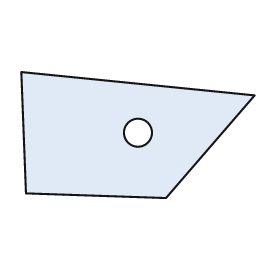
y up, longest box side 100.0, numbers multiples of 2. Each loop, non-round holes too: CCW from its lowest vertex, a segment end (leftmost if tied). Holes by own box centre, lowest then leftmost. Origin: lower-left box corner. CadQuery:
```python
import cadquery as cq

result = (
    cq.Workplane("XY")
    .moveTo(62.0, 0.0)
    .lineTo(100.0, 44.0)
    .lineTo(0.0, 54.0)
    .lineTo(2.0, 2.0)
    .close()
    .moveTo(50.0, 28.0)
    .circle(6.0)
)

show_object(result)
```